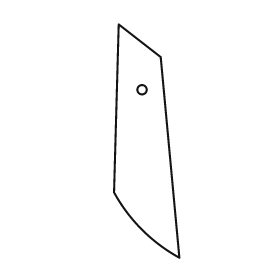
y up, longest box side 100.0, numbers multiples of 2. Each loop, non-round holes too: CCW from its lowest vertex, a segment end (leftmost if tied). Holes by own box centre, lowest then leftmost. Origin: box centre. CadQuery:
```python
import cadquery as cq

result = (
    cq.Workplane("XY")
    .moveTo(14.0, -50.0)
    .lineTo(6.0, 36.0)
    .lineTo(-12.0, 50.0)
    .lineTo(-14.0, -22.0)
    .threePointArc((-2.0, -38.0), (14.0, -50.0))
    .close()
    .moveTo(-2.0, 22.0)
    .circle(2.0)
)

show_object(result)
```